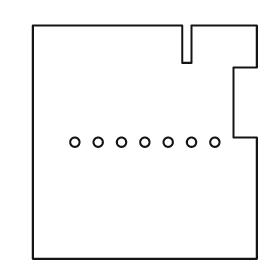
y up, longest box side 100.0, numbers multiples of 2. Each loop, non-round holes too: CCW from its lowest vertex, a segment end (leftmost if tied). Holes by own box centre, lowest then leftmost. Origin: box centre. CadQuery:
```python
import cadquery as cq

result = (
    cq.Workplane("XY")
    .moveTo(-48.0, -50.0)
    .lineTo(48.0, -50.0)
    .lineTo(48.0, 2.0)
    .lineTo(38.0, 2.0)
    .lineTo(38.0, 32.0)
    .lineTo(48.0, 32.0)
    .lineTo(48.0, 50.0)
    .lineTo(20.0, 50.0)
    .lineTo(20.0, 34.0)
    .lineTo(16.0, 34.0)
    .lineTo(16.0, 50.0)
    .lineTo(-48.0, 50.0)
    .close()
    .moveTo(-30.0, 0.0)
    .circle(2.0)
    .moveTo(-20.0, 0.0)
    .circle(2.0)
    .moveTo(-10.0, 0.0)
    .circle(2.0)
    .moveTo(0.0, 0.0)
    .circle(2.0)
    .moveTo(10.0, 0.0)
    .circle(2.0)
    .moveTo(20.0, 0.0)
    .circle(2.0)
    .moveTo(30.0, 0.0)
    .circle(2.0)
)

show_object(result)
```